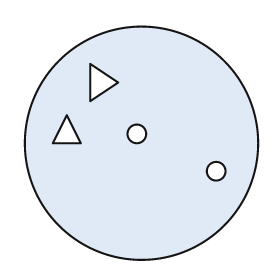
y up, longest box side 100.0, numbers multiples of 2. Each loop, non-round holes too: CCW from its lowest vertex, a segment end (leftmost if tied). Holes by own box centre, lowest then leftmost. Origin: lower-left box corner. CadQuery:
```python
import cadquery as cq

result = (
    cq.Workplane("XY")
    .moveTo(50.0, 50.0)
    .circle(50.0)
    .moveTo(82.0, 38.0)
    .circle(4.0)
    .moveTo(48.0, 54.0)
    .circle(4.0)
    .moveTo(12.0, 50.0)
    .lineTo(24.0, 50.0)
    .lineTo(18.0, 62.0)
    .close()
    .moveTo(28.0, 68.0)
    .lineTo(40.0, 76.0)
    .lineTo(28.0, 84.0)
    .close()
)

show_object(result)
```